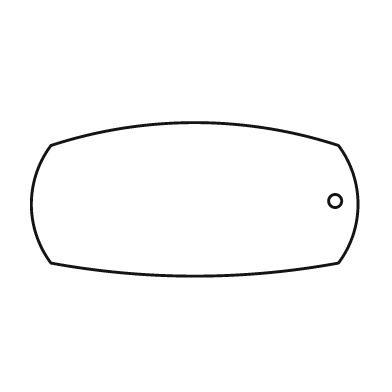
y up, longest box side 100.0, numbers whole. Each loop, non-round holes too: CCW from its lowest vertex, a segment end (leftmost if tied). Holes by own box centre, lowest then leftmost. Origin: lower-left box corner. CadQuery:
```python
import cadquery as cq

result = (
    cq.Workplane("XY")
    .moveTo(6.0, 4.0)
    .threePointArc((50.0, 0.0), (94.0, 4.0))
    .threePointArc((100.0, 22.0), (94.0, 40.0))
    .threePointArc((50.0, 47.0), (6.0, 40.0))
    .threePointArc((0.0, 22.0), (6.0, 4.0))
    .close()
    .moveTo(93.0, 23.0)
    .circle(2.0)
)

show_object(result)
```